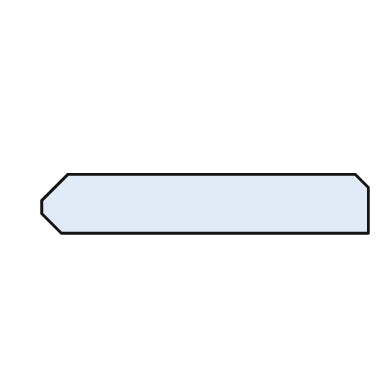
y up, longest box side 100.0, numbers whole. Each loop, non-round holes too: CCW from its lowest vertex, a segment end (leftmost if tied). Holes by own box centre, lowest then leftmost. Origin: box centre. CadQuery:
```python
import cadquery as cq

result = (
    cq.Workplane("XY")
    .moveTo(-44.0, -9.0)
    .lineTo(50.0, -9.0)
    .lineTo(50.0, 5.0)
    .lineTo(46.0, 9.0)
    .lineTo(-42.0, 9.0)
    .lineTo(-50.0, 1.0)
    .lineTo(-50.0, -3.0)
    .close()
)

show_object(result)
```